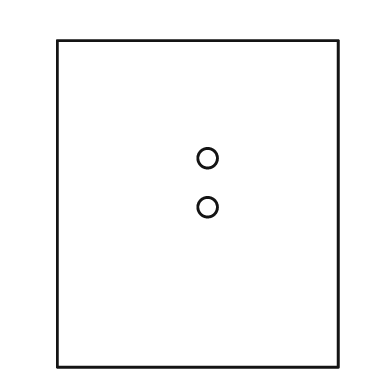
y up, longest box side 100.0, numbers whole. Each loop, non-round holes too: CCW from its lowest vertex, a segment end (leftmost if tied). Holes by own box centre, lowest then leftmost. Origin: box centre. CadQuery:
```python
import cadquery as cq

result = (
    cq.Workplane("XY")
    .moveTo(-43.0, -50.0)
    .lineTo(43.0, -50.0)
    .lineTo(43.0, 50.0)
    .lineTo(-43.0, 50.0)
    .close()
    .moveTo(3.0, -1.0)
    .circle(3.0)
    .moveTo(3.0, 14.0)
    .circle(3.0)
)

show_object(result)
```